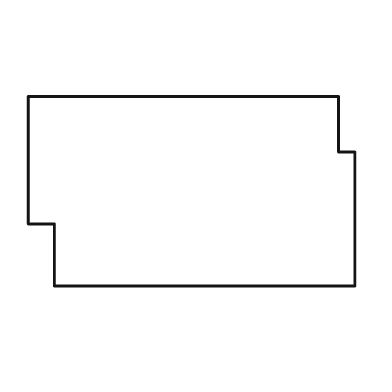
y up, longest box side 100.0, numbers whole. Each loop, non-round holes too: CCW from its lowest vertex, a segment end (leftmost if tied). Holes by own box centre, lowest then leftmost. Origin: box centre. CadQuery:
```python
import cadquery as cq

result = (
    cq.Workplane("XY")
    .moveTo(-42.0, -29.0)
    .lineTo(50.0, -29.0)
    .lineTo(50.0, 12.0)
    .lineTo(45.0, 12.0)
    .lineTo(45.0, 29.0)
    .lineTo(-50.0, 29.0)
    .lineTo(-50.0, -10.0)
    .lineTo(-42.0, -10.0)
    .close()
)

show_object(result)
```